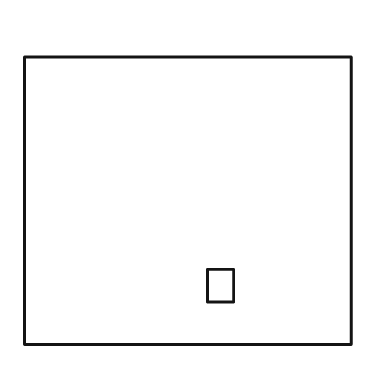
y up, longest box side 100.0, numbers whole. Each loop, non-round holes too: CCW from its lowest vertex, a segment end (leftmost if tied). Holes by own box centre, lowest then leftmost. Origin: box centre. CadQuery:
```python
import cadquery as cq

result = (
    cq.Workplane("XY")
    .moveTo(-50.0, -44.0)
    .lineTo(50.0, -44.0)
    .lineTo(50.0, 44.0)
    .lineTo(-50.0, 44.0)
    .close()
    .moveTo(6.0, -31.0)
    .lineTo(14.0, -31.0)
    .lineTo(14.0, -21.0)
    .lineTo(6.0, -21.0)
    .close()
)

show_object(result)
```